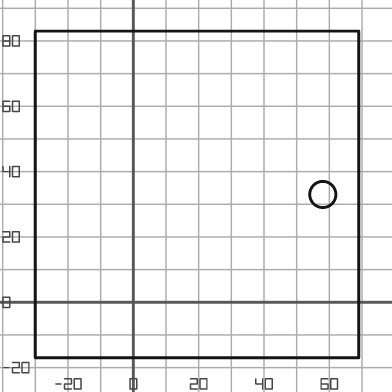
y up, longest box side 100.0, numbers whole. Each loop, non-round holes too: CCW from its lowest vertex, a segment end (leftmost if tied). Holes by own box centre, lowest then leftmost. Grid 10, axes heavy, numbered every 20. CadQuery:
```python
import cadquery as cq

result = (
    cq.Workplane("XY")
    .moveTo(-30.0, -17.0)
    .lineTo(69.0, -17.0)
    .lineTo(69.0, 83.0)
    .lineTo(-30.0, 83.0)
    .close()
    .moveTo(58.0, 33.0)
    .circle(4.0)
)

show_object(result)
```